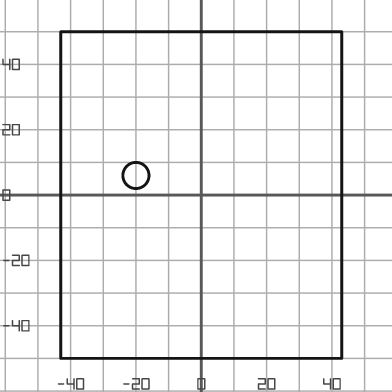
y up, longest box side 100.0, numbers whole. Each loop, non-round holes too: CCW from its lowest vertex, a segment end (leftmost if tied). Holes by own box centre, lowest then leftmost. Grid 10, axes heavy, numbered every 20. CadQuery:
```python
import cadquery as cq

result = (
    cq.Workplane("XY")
    .moveTo(-43.0, -50.0)
    .lineTo(43.0, -50.0)
    .lineTo(43.0, 50.0)
    .lineTo(-43.0, 50.0)
    .close()
    .moveTo(-20.0, 6.0)
    .circle(4.0)
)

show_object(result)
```